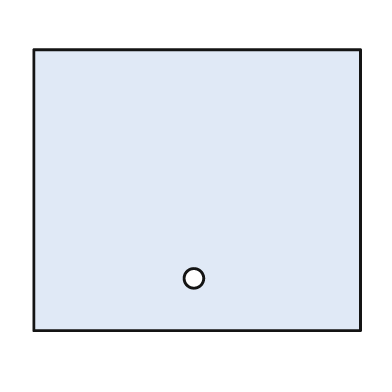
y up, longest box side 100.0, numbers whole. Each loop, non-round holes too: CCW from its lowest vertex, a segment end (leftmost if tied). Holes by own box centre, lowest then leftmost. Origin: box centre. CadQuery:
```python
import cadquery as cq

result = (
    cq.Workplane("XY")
    .moveTo(-50.0, -43.0)
    .lineTo(50.0, -43.0)
    .lineTo(50.0, 43.0)
    .lineTo(-50.0, 43.0)
    .close()
    .moveTo(-1.0, -27.0)
    .circle(3.0)
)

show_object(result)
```